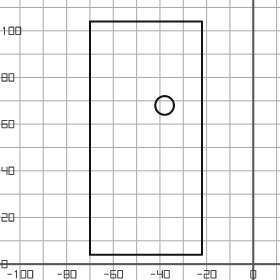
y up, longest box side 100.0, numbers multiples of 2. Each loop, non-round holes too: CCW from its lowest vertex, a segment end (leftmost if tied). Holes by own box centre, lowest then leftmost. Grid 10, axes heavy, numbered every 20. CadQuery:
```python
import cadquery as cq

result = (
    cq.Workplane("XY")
    .moveTo(-70.0, 4.0)
    .lineTo(-22.0, 4.0)
    .lineTo(-22.0, 104.0)
    .lineTo(-70.0, 104.0)
    .close()
    .moveTo(-38.0, 68.0)
    .circle(4.0)
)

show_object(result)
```